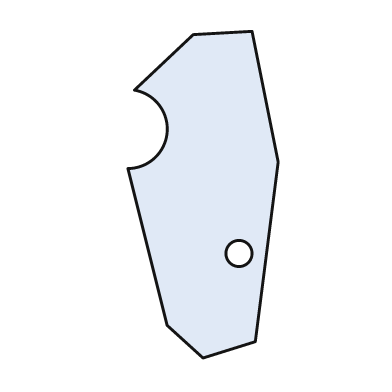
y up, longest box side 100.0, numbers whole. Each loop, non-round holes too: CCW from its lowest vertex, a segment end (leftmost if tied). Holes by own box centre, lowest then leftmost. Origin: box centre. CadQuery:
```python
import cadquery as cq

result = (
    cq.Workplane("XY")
    .moveTo(0.0, -50.0)
    .lineTo(16.0, -45.0)
    .lineTo(23.0, 10.0)
    .lineTo(15.0, 50.0)
    .lineTo(-3.0, 49.0)
    .lineTo(-21.0, 32.0)
    .threePointArc((-11.0, 19.0), (-23.0, 8.0))
    .lineTo(-11.0, -40.0)
    .close()
    .moveTo(11.0, -18.0)
    .circle(4.0)
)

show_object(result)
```